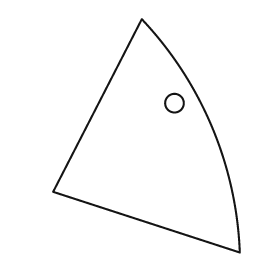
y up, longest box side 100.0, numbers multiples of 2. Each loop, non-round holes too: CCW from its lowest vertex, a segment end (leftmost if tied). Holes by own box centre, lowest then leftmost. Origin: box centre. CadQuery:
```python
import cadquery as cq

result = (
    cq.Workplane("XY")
    .moveTo(40.0, -50.0)
    .threePointArc((28.0, 4.0), (-2.0, 50.0))
    .lineTo(-40.0, -24.0)
    .close()
    .moveTo(12.0, 14.0)
    .circle(4.0)
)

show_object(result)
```